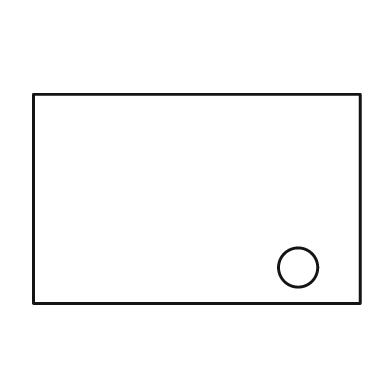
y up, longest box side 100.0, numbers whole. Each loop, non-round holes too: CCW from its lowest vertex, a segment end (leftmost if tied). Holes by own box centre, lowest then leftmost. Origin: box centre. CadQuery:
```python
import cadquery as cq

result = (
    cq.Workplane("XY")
    .moveTo(-50.0, -32.0)
    .lineTo(50.0, -32.0)
    .lineTo(50.0, 32.0)
    .lineTo(-50.0, 32.0)
    .close()
    .moveTo(31.0, -21.0)
    .circle(6.0)
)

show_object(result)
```